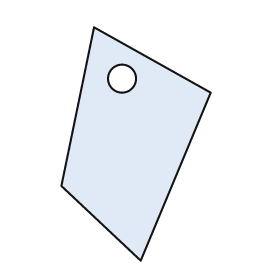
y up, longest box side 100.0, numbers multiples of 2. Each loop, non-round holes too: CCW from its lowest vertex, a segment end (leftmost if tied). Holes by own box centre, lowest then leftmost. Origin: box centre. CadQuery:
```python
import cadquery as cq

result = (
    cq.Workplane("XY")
    .moveTo(2.0, -50.0)
    .lineTo(32.0, 22.0)
    .lineTo(-18.0, 50.0)
    .lineTo(-32.0, -18.0)
    .close()
    .moveTo(-6.0, 28.0)
    .circle(6.0)
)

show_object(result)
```